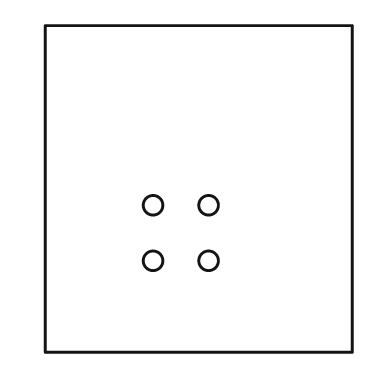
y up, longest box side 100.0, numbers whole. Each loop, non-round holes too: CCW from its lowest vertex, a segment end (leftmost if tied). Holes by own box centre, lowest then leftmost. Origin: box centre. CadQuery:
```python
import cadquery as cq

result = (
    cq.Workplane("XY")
    .moveTo(-47.0, -50.0)
    .lineTo(47.0, -50.0)
    .lineTo(47.0, 50.0)
    .lineTo(-47.0, 50.0)
    .close()
    .moveTo(-14.0, -22.0)
    .circle(3.0)
    .moveTo(3.0, -22.0)
    .circle(3.0)
    .moveTo(-14.0, -5.0)
    .circle(3.0)
    .moveTo(3.0, -5.0)
    .circle(3.0)
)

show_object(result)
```